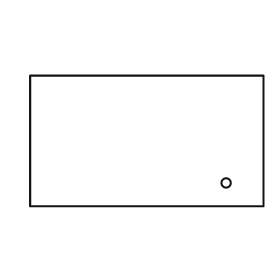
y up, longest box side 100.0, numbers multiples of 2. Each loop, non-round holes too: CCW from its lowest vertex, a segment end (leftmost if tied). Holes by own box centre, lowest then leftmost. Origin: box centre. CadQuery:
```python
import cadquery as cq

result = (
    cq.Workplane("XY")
    .moveTo(-50.0, -28.0)
    .lineTo(50.0, -28.0)
    .lineTo(50.0, 28.0)
    .lineTo(-50.0, 28.0)
    .close()
    .moveTo(34.0, -18.0)
    .circle(2.0)
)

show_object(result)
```